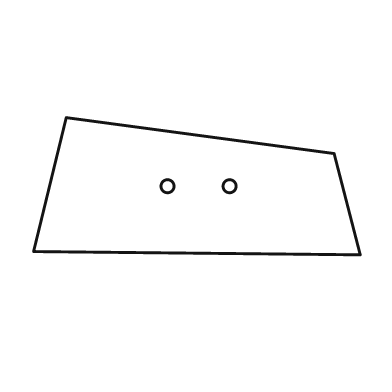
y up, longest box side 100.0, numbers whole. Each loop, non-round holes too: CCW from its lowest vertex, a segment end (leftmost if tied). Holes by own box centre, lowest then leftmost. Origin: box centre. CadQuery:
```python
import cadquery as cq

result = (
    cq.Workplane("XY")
    .moveTo(50.0, -21.0)
    .lineTo(42.0, 10.0)
    .lineTo(-40.0, 21.0)
    .lineTo(-50.0, -20.0)
    .close()
    .moveTo(-9.0, 0.0)
    .circle(2.0)
    .moveTo(10.0, 0.0)
    .circle(2.0)
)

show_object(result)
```